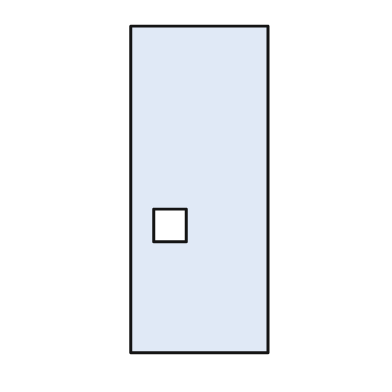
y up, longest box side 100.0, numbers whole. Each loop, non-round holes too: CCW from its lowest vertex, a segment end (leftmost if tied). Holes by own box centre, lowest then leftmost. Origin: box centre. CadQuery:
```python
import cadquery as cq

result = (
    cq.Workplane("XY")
    .moveTo(-21.0, -50.0)
    .lineTo(21.0, -50.0)
    .lineTo(21.0, 50.0)
    .lineTo(-21.0, 50.0)
    .close()
    .moveTo(-14.0, -16.0)
    .lineTo(-4.0, -16.0)
    .lineTo(-4.0, -6.0)
    .lineTo(-14.0, -6.0)
    .close()
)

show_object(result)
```